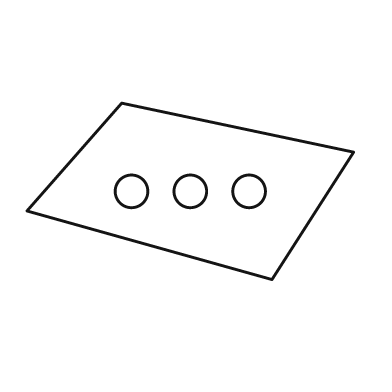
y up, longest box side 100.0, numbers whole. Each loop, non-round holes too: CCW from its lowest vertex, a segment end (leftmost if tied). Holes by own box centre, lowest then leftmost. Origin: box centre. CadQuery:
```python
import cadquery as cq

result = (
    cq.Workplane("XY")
    .moveTo(25.0, -27.0)
    .lineTo(50.0, 12.0)
    .lineTo(-21.0, 27.0)
    .lineTo(-50.0, -6.0)
    .close()
    .moveTo(-18.0, 0.0)
    .circle(5.0)
    .moveTo(0.0, 0.0)
    .circle(5.0)
    .moveTo(18.0, 0.0)
    .circle(5.0)
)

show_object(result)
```